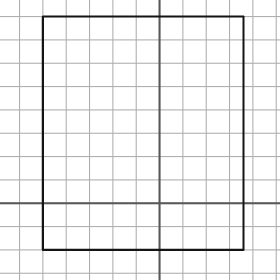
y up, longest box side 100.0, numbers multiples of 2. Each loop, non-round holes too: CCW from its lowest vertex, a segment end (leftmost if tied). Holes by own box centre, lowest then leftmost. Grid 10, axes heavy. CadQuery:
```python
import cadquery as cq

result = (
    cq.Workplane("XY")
    .moveTo(-50.0, -20.0)
    .lineTo(36.0, -20.0)
    .lineTo(36.0, 80.0)
    .lineTo(-50.0, 80.0)
    .close()
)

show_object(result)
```